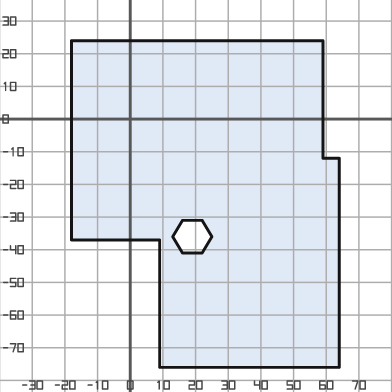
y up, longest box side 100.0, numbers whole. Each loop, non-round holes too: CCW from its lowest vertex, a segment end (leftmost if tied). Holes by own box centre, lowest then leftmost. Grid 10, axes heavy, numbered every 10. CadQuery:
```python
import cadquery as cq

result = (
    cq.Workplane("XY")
    .moveTo(9.0, -76.0)
    .lineTo(64.0, -76.0)
    .lineTo(64.0, -12.0)
    .lineTo(59.0, -12.0)
    .lineTo(59.0, 24.0)
    .lineTo(-18.0, 24.0)
    .lineTo(-18.0, -37.0)
    .lineTo(9.0, -37.0)
    .close()
    .moveTo(16.0, -41.0)
    .lineTo(22.0, -41.0)
    .lineTo(25.0, -36.0)
    .lineTo(22.0, -31.0)
    .lineTo(16.0, -31.0)
    .lineTo(13.0, -36.0)
    .close()
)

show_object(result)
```